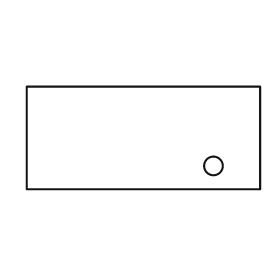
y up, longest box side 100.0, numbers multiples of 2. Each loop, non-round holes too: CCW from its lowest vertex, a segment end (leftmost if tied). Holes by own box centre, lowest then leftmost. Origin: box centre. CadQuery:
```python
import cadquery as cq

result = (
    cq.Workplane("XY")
    .moveTo(-50.0, -22.0)
    .lineTo(50.0, -22.0)
    .lineTo(50.0, 22.0)
    .lineTo(-50.0, 22.0)
    .close()
    .moveTo(30.0, -12.0)
    .circle(4.0)
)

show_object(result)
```